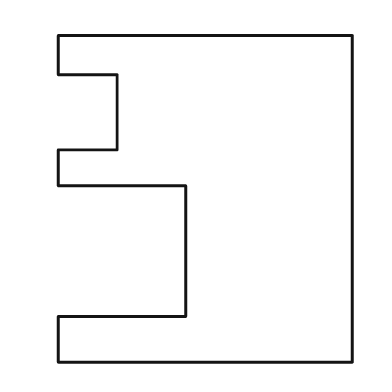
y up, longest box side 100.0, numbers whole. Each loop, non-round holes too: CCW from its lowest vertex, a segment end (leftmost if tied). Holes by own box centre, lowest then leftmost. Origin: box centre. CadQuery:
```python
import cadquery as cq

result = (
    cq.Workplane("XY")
    .moveTo(-45.0, -50.0)
    .lineTo(45.0, -50.0)
    .lineTo(45.0, 50.0)
    .lineTo(-45.0, 50.0)
    .lineTo(-45.0, 38.0)
    .lineTo(-27.0, 38.0)
    .lineTo(-27.0, 15.0)
    .lineTo(-45.0, 15.0)
    .lineTo(-45.0, 4.0)
    .lineTo(-6.0, 4.0)
    .lineTo(-6.0, -36.0)
    .lineTo(-45.0, -36.0)
    .close()
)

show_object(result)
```